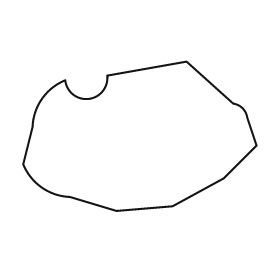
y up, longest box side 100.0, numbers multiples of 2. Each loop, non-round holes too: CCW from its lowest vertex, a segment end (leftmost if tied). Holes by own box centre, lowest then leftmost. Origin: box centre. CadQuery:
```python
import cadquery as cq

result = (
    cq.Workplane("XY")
    .moveTo(-10.0, -32.0)
    .lineTo(14.0, -30.0)
    .lineTo(36.0, -18.0)
    .lineTo(50.0, -4.0)
    .lineTo(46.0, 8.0)
    .threePointArc((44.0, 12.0), (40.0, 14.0))
    .lineTo(20.0, 32.0)
    .lineTo(-14.0, 26.0)
    .threePointArc((-22.0, 16.0), (-32.0, 24.0))
    .threePointArc((-42.0, 16.0), (-46.0, 4.0))
    .lineTo(-50.0, -12.0)
    .threePointArc((-42.0, -22.0), (-30.0, -26.0))
    .close()
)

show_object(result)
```